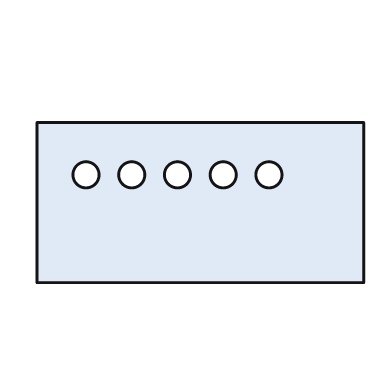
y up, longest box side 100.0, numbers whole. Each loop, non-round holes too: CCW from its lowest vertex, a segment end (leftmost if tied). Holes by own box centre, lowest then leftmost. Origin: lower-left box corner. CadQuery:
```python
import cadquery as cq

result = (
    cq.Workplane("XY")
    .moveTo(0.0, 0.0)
    .lineTo(100.0, 0.0)
    .lineTo(100.0, 49.0)
    .lineTo(0.0, 49.0)
    .close()
    .moveTo(15.0, 33.0)
    .circle(4.0)
    .moveTo(29.0, 33.0)
    .circle(4.0)
    .moveTo(43.0, 33.0)
    .circle(4.0)
    .moveTo(57.0, 33.0)
    .circle(4.0)
    .moveTo(71.0, 33.0)
    .circle(4.0)
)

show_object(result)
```